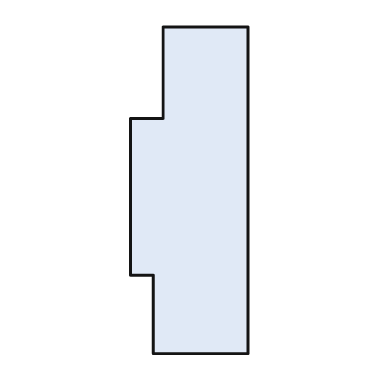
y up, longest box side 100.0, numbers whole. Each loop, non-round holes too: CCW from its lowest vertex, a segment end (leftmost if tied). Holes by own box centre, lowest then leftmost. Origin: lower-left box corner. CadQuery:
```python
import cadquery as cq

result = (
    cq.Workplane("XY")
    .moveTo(7.0, 0.0)
    .lineTo(36.0, 0.0)
    .lineTo(36.0, 100.0)
    .lineTo(10.0, 100.0)
    .lineTo(10.0, 72.0)
    .lineTo(0.0, 72.0)
    .lineTo(0.0, 24.0)
    .lineTo(7.0, 24.0)
    .close()
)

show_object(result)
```